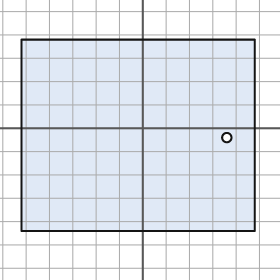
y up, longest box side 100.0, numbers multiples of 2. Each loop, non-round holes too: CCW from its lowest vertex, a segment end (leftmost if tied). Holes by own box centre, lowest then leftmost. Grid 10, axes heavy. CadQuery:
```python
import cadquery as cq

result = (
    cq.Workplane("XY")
    .moveTo(-52.0, -44.0)
    .lineTo(48.0, -44.0)
    .lineTo(48.0, 38.0)
    .lineTo(-52.0, 38.0)
    .close()
    .moveTo(36.0, -4.0)
    .circle(2.0)
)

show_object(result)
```